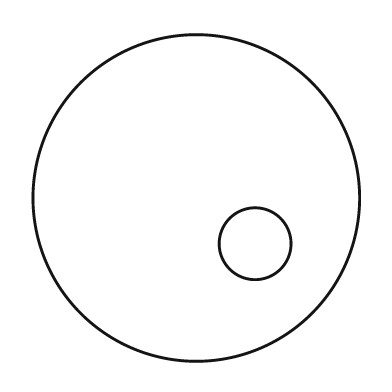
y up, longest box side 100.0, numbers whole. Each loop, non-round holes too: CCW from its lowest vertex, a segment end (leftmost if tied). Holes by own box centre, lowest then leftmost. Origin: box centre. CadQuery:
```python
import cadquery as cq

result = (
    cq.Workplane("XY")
    .moveTo(0.0, 0.0)
    .circle(50.0)
    .moveTo(18.0, -14.0)
    .circle(11.0)
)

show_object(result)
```